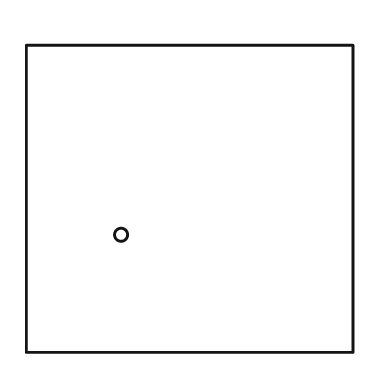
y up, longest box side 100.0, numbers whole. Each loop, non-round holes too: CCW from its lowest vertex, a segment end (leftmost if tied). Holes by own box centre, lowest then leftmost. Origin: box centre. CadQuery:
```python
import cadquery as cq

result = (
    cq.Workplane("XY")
    .moveTo(-50.0, -47.0)
    .lineTo(50.0, -47.0)
    .lineTo(50.0, 47.0)
    .lineTo(-50.0, 47.0)
    .close()
    .moveTo(-21.0, -11.0)
    .circle(2.0)
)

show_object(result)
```